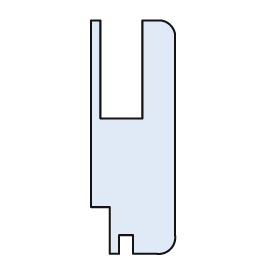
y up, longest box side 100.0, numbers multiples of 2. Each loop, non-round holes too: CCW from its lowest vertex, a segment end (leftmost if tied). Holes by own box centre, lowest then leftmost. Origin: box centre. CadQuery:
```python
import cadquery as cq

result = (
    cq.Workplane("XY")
    .moveTo(-10.0, -50.0)
    .lineTo(-6.0, -50.0)
    .lineTo(-6.0, -42.0)
    .lineTo(0.0, -42.0)
    .lineTo(0.0, -50.0)
    .lineTo(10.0, -50.0)
    .threePointArc((16.0, -48.0), (18.0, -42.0))
    .lineTo(18.0, 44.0)
    .threePointArc((16.0, 48.0), (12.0, 50.0))
    .lineTo(4.0, 50.0)
    .lineTo(4.0, 8.0)
    .lineTo(-14.0, 8.0)
    .lineTo(-14.0, 50.0)
    .lineTo(-18.0, 50.0)
    .lineTo(-18.0, -30.0)
    .lineTo(-10.0, -30.0)
    .close()
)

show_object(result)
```